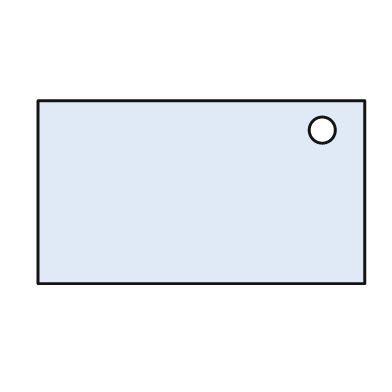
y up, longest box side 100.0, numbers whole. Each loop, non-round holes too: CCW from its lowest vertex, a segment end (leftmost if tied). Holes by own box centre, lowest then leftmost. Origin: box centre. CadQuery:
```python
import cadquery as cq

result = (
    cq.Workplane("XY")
    .moveTo(-50.0, -28.0)
    .lineTo(50.0, -28.0)
    .lineTo(50.0, 28.0)
    .lineTo(-50.0, 28.0)
    .close()
    .moveTo(37.0, 19.0)
    .circle(4.0)
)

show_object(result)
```